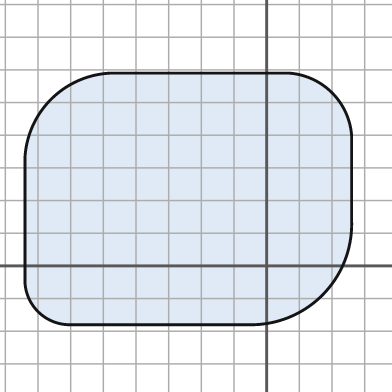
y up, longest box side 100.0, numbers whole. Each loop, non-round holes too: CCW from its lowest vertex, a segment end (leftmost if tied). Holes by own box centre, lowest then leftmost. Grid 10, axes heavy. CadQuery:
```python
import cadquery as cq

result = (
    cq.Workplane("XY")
    .moveTo(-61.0, -18.0)
    .lineTo(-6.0, -18.0)
    .threePointArc((17.0, -9.0), (26.0, 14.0))
    .lineTo(26.0, 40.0)
    .threePointArc((20.0, 53.0), (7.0, 59.0))
    .lineTo(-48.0, 59.0)
    .threePointArc((-66.0, 51.0), (-74.0, 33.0))
    .lineTo(-74.0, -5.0)
    .threePointArc((-70.0, -14.0), (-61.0, -18.0))
    .close()
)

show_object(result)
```